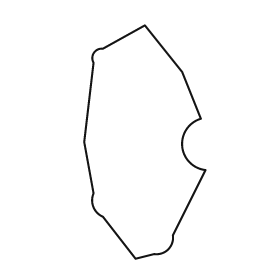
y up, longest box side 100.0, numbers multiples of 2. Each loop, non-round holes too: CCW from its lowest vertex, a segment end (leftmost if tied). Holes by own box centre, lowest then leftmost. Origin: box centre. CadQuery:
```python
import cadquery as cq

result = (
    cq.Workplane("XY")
    .moveTo(-4.0, -50.0)
    .lineTo(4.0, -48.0)
    .threePointArc((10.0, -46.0), (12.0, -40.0))
    .lineTo(26.0, -12.0)
    .threePointArc((16.0, -2.0), (24.0, 10.0))
    .lineTo(16.0, 30.0)
    .lineTo(0.0, 50.0)
    .lineTo(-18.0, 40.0)
    .threePointArc((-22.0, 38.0), (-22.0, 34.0))
    .lineTo(-26.0, 0.0)
    .lineTo(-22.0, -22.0)
    .threePointArc((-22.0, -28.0), (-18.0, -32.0))
    .close()
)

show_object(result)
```